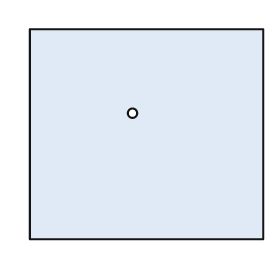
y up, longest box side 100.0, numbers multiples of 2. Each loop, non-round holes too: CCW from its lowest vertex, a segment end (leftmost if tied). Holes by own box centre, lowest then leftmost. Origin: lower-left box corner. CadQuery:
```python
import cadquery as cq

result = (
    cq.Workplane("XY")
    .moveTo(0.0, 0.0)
    .lineTo(100.0, 0.0)
    .lineTo(100.0, 90.0)
    .lineTo(0.0, 90.0)
    .close()
    .moveTo(44.0, 54.0)
    .circle(2.0)
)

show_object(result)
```